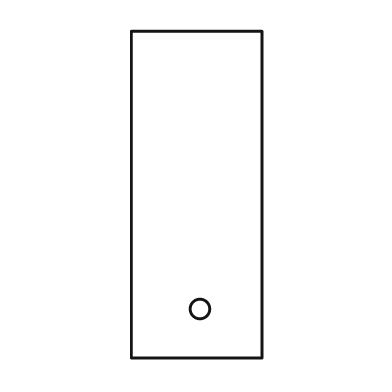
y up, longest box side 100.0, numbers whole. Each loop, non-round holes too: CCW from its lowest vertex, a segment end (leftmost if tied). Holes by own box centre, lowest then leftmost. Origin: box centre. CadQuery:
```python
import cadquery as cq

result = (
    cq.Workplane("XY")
    .moveTo(-20.0, -50.0)
    .lineTo(20.0, -50.0)
    .lineTo(20.0, 50.0)
    .lineTo(-20.0, 50.0)
    .close()
    .moveTo(1.0, -35.0)
    .circle(3.0)
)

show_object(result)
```